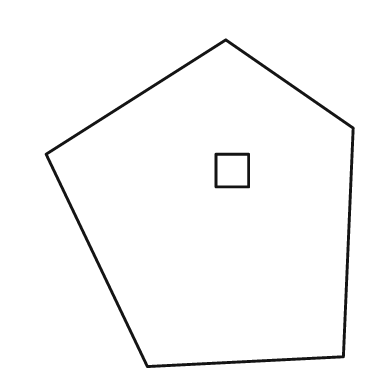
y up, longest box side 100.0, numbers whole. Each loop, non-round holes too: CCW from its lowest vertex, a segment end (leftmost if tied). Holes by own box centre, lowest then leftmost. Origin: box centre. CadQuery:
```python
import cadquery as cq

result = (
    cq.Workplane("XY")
    .moveTo(-16.0, -50.0)
    .lineTo(44.0, -47.0)
    .lineTo(47.0, 23.0)
    .lineTo(8.0, 50.0)
    .lineTo(-47.0, 15.0)
    .close()
    .moveTo(5.0, 5.0)
    .lineTo(15.0, 5.0)
    .lineTo(15.0, 15.0)
    .lineTo(5.0, 15.0)
    .close()
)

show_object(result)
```